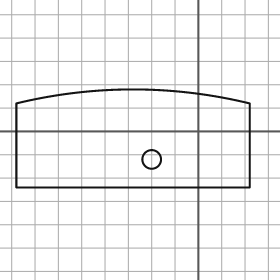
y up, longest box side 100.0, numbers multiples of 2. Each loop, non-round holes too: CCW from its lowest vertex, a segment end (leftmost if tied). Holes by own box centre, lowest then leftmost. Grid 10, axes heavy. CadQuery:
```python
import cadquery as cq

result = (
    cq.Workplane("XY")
    .moveTo(-78.0, -24.0)
    .lineTo(22.0, -24.0)
    .lineTo(22.0, 12.0)
    .threePointArc((-28.0, 18.0), (-78.0, 12.0))
    .close()
    .moveTo(-20.0, -12.0)
    .circle(4.0)
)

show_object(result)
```